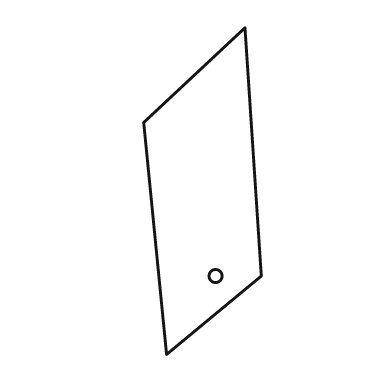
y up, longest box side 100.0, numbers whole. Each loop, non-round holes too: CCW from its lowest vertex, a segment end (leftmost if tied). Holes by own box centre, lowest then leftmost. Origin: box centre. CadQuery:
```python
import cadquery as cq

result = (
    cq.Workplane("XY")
    .moveTo(-11.0, -50.0)
    .lineTo(18.0, -26.0)
    .lineTo(13.0, 50.0)
    .lineTo(-18.0, 21.0)
    .close()
    .moveTo(4.0, -26.0)
    .circle(2.0)
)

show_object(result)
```